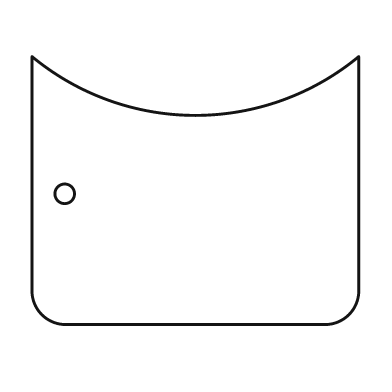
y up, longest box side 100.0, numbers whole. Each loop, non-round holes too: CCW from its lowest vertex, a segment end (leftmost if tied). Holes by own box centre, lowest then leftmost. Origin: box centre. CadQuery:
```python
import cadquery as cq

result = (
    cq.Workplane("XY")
    .moveTo(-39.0, -41.0)
    .lineTo(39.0, -41.0)
    .threePointArc((47.0, -38.0), (50.0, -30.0))
    .lineTo(50.0, 41.0)
    .threePointArc((0.0, 23.0), (-50.0, 41.0))
    .lineTo(-50.0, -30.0)
    .threePointArc((-47.0, -38.0), (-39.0, -41.0))
    .close()
    .moveTo(-40.0, -1.0)
    .circle(3.0)
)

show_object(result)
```